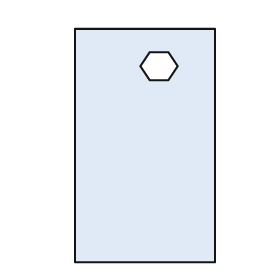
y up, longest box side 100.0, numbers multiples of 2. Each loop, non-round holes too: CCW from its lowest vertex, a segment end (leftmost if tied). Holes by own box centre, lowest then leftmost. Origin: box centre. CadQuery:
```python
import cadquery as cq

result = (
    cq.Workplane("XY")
    .moveTo(-30.0, -50.0)
    .lineTo(30.0, -50.0)
    .lineTo(30.0, 50.0)
    .lineTo(-30.0, 50.0)
    .close()
    .moveTo(2.0, 28.0)
    .lineTo(10.0, 28.0)
    .lineTo(14.0, 34.0)
    .lineTo(10.0, 40.0)
    .lineTo(2.0, 40.0)
    .lineTo(-2.0, 34.0)
    .close()
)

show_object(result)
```